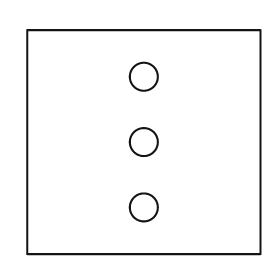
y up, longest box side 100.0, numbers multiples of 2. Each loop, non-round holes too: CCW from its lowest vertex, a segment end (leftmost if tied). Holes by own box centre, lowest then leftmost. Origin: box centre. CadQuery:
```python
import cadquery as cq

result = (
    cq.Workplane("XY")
    .moveTo(-50.0, -48.0)
    .lineTo(50.0, -48.0)
    .lineTo(50.0, 48.0)
    .lineTo(-50.0, 48.0)
    .close()
    .moveTo(0.0, -28.0)
    .circle(6.0)
    .moveTo(0.0, 0.0)
    .circle(6.0)
    .moveTo(0.0, 28.0)
    .circle(6.0)
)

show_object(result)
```